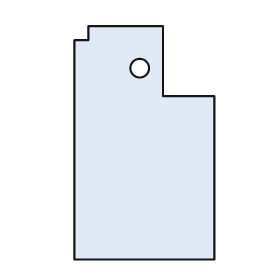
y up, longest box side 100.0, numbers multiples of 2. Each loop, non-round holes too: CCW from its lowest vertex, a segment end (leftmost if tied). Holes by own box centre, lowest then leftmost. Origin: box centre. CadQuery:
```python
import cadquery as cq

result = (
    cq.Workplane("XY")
    .moveTo(-30.0, -50.0)
    .lineTo(30.0, -50.0)
    .lineTo(30.0, 20.0)
    .lineTo(8.0, 20.0)
    .lineTo(8.0, 50.0)
    .lineTo(-24.0, 50.0)
    .lineTo(-24.0, 44.0)
    .lineTo(-30.0, 44.0)
    .close()
    .moveTo(-2.0, 32.0)
    .circle(4.0)
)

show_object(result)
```